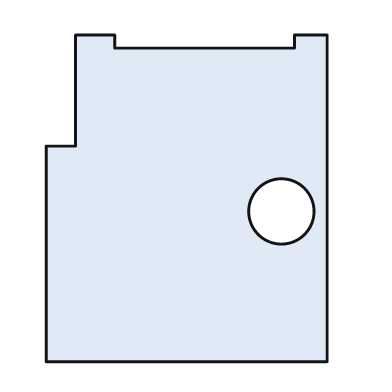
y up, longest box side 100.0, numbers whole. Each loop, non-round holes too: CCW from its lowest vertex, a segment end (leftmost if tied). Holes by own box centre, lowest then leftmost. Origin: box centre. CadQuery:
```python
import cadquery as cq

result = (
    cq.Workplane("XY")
    .moveTo(-43.0, -50.0)
    .lineTo(43.0, -50.0)
    .lineTo(43.0, 50.0)
    .lineTo(33.0, 50.0)
    .lineTo(33.0, 46.0)
    .lineTo(-22.0, 46.0)
    .lineTo(-22.0, 50.0)
    .lineTo(-34.0, 50.0)
    .lineTo(-34.0, 16.0)
    .lineTo(-43.0, 16.0)
    .close()
    .moveTo(29.0, -4.0)
    .circle(10.0)
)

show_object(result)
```